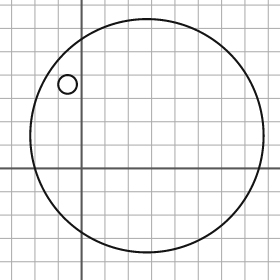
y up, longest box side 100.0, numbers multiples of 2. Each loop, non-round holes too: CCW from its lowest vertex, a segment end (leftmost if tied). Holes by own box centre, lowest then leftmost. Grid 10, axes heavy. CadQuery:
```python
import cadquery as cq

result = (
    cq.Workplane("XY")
    .moveTo(28.0, 14.0)
    .circle(50.0)
    .moveTo(-6.0, 36.0)
    .circle(4.0)
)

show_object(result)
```